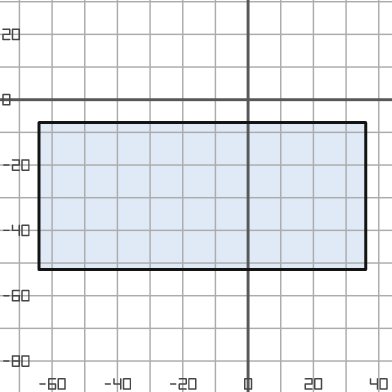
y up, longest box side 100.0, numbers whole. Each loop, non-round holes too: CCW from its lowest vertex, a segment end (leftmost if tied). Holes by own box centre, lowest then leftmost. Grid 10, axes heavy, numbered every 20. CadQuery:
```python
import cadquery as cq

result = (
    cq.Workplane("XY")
    .moveTo(-64.0, -52.0)
    .lineTo(36.0, -52.0)
    .lineTo(36.0, -7.0)
    .lineTo(-64.0, -7.0)
    .close()
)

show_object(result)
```